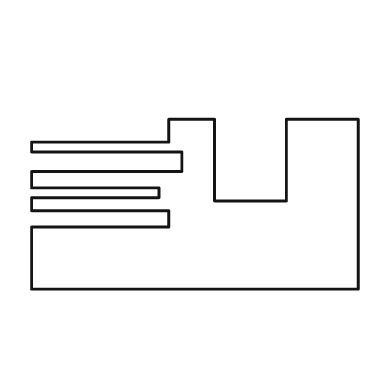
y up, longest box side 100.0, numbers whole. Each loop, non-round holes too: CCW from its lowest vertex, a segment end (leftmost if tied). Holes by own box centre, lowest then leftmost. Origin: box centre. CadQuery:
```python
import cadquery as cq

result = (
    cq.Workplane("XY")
    .moveTo(-50.0, -26.0)
    .lineTo(50.0, -26.0)
    .lineTo(50.0, 26.0)
    .lineTo(28.0, 26.0)
    .lineTo(28.0, 1.0)
    .lineTo(6.0, 1.0)
    .lineTo(6.0, 26.0)
    .lineTo(-8.0, 26.0)
    .lineTo(-8.0, 19.0)
    .lineTo(-50.0, 19.0)
    .lineTo(-50.0, 16.0)
    .lineTo(-4.0, 16.0)
    .lineTo(-4.0, 10.0)
    .lineTo(-50.0, 10.0)
    .lineTo(-50.0, 5.0)
    .lineTo(-11.0, 5.0)
    .lineTo(-11.0, 2.0)
    .lineTo(-50.0, 2.0)
    .lineTo(-50.0, -2.0)
    .lineTo(-8.0, -2.0)
    .lineTo(-8.0, -7.0)
    .lineTo(-50.0, -7.0)
    .close()
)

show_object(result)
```